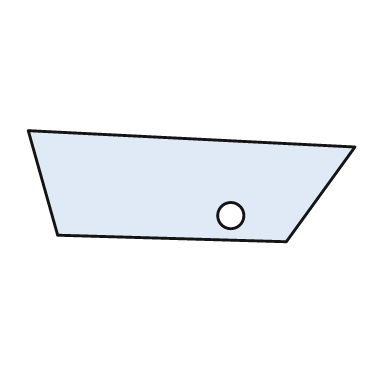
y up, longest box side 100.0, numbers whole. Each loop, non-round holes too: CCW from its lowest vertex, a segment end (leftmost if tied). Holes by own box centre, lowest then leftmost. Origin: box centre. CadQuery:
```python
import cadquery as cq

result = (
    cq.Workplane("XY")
    .moveTo(29.0, -17.0)
    .lineTo(50.0, 12.0)
    .lineTo(-50.0, 17.0)
    .lineTo(-41.0, -15.0)
    .close()
    .moveTo(12.0, -9.0)
    .circle(4.0)
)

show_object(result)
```